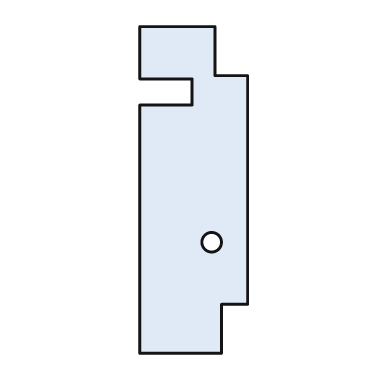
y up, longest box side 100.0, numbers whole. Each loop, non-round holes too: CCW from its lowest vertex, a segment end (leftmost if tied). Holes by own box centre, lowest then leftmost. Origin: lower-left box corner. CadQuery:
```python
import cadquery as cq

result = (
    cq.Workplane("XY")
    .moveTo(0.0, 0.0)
    .lineTo(25.0, 0.0)
    .lineTo(25.0, 15.0)
    .lineTo(33.0, 15.0)
    .lineTo(33.0, 85.0)
    .lineTo(23.0, 85.0)
    .lineTo(23.0, 100.0)
    .lineTo(0.0, 100.0)
    .lineTo(0.0, 84.0)
    .lineTo(16.0, 84.0)
    .lineTo(16.0, 76.0)
    .lineTo(0.0, 76.0)
    .close()
    .moveTo(22.0, 34.0)
    .circle(3.0)
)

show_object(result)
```